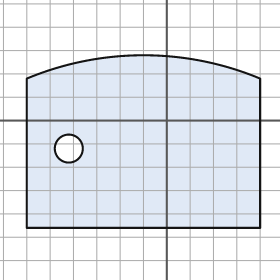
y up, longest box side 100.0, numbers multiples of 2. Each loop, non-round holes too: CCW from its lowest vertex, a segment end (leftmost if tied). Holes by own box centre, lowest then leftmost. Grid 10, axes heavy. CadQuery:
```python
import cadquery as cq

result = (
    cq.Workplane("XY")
    .moveTo(-60.0, -46.0)
    .lineTo(40.0, -46.0)
    .lineTo(40.0, 18.0)
    .threePointArc((-10.0, 28.0), (-60.0, 18.0))
    .close()
    .moveTo(-42.0, -12.0)
    .circle(6.0)
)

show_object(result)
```